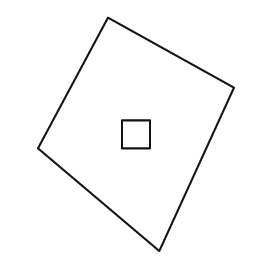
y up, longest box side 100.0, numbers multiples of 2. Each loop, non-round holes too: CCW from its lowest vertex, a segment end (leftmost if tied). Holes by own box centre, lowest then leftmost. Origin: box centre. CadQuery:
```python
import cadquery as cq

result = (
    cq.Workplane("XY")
    .moveTo(10.0, -50.0)
    .lineTo(42.0, 20.0)
    .lineTo(-12.0, 50.0)
    .lineTo(-42.0, -6.0)
    .close()
    .moveTo(-6.0, -6.0)
    .lineTo(6.0, -6.0)
    .lineTo(6.0, 6.0)
    .lineTo(-6.0, 6.0)
    .close()
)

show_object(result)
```